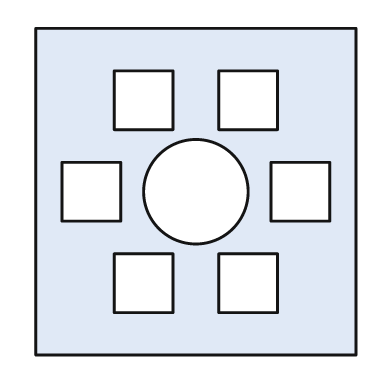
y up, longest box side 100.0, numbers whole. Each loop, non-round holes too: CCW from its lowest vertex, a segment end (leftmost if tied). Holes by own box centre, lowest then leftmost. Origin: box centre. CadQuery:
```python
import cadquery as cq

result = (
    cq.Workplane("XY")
    .moveTo(-49.0, -50.0)
    .lineTo(49.0, -50.0)
    .lineTo(49.0, 50.0)
    .lineTo(-49.0, 50.0)
    .close()
    .moveTo(-25.0, -37.0)
    .lineTo(-7.0, -37.0)
    .lineTo(-7.0, -19.0)
    .lineTo(-25.0, -19.0)
    .close()
    .moveTo(7.0, -37.0)
    .lineTo(25.0, -37.0)
    .lineTo(25.0, -19.0)
    .lineTo(7.0, -19.0)
    .close()
    .moveTo(-41.0, -9.0)
    .lineTo(-23.0, -9.0)
    .lineTo(-23.0, 9.0)
    .lineTo(-41.0, 9.0)
    .close()
    .moveTo(0.0, 0.0)
    .circle(16.0)
    .moveTo(23.0, -9.0)
    .lineTo(41.0, -9.0)
    .lineTo(41.0, 9.0)
    .lineTo(23.0, 9.0)
    .close()
    .moveTo(-25.0, 19.0)
    .lineTo(-7.0, 19.0)
    .lineTo(-7.0, 37.0)
    .lineTo(-25.0, 37.0)
    .close()
    .moveTo(7.0, 19.0)
    .lineTo(25.0, 19.0)
    .lineTo(25.0, 37.0)
    .lineTo(7.0, 37.0)
    .close()
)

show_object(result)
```